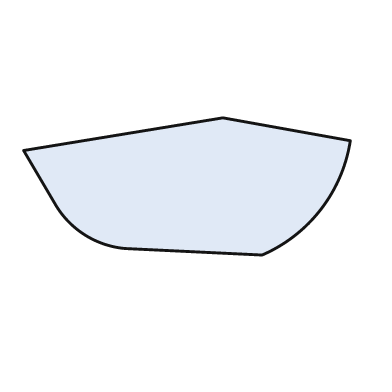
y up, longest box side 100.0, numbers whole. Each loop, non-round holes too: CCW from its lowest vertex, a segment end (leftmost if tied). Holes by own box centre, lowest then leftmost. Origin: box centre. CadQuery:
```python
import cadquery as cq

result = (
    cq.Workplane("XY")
    .moveTo(23.0, -21.0)
    .threePointArc((41.0, -7.0), (50.0, 14.0))
    .lineTo(11.0, 21.0)
    .lineTo(-50.0, 11.0)
    .lineTo(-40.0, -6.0)
    .threePointArc((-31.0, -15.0), (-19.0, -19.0))
    .close()
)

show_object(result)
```